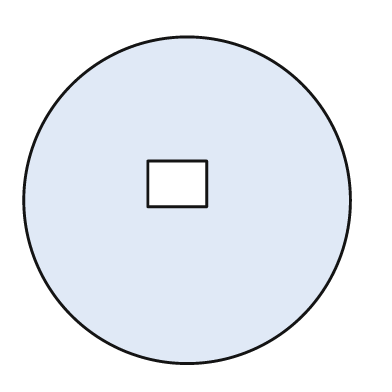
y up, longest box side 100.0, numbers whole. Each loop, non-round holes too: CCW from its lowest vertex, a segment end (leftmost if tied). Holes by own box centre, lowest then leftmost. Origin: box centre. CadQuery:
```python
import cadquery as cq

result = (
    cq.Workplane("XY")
    .moveTo(0.0, 0.0)
    .circle(50.0)
    .moveTo(-12.0, -2.0)
    .lineTo(6.0, -2.0)
    .lineTo(6.0, 12.0)
    .lineTo(-12.0, 12.0)
    .close()
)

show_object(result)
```